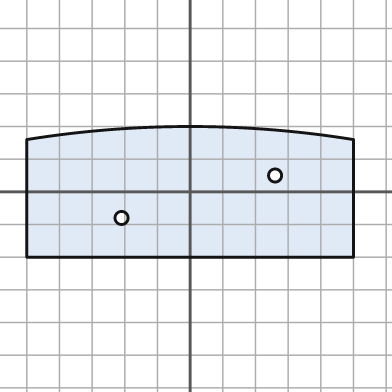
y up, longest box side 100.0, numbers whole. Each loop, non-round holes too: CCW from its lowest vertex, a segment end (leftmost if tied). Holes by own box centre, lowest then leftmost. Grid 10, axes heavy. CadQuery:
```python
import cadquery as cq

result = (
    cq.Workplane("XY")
    .moveTo(-50.0, -20.0)
    .lineTo(50.0, -20.0)
    .lineTo(50.0, 16.0)
    .threePointArc((0.0, 20.0), (-50.0, 16.0))
    .close()
    .moveTo(-21.0, -8.0)
    .circle(2.0)
    .moveTo(26.0, 5.0)
    .circle(2.0)
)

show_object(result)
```